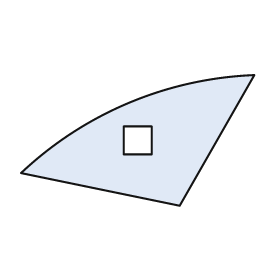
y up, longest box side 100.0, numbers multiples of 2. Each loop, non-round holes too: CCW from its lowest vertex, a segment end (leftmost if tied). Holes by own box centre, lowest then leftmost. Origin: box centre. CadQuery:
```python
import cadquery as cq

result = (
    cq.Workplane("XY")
    .moveTo(18.0, -28.0)
    .lineTo(50.0, 28.0)
    .threePointArc((-4.0, 16.0), (-50.0, -14.0))
    .close()
    .moveTo(-6.0, -6.0)
    .lineTo(6.0, -6.0)
    .lineTo(6.0, 6.0)
    .lineTo(-6.0, 6.0)
    .close()
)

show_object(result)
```